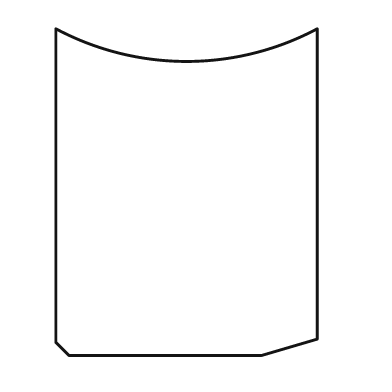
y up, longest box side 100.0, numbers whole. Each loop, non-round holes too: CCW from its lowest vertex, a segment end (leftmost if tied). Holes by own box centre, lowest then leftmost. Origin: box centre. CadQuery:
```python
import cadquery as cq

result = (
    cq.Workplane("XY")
    .moveTo(-36.0, -50.0)
    .lineTo(23.0, -50.0)
    .lineTo(40.0, -45.0)
    .lineTo(40.0, 50.0)
    .threePointArc((0.0, 40.0), (-40.0, 50.0))
    .lineTo(-40.0, -46.0)
    .close()
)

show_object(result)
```